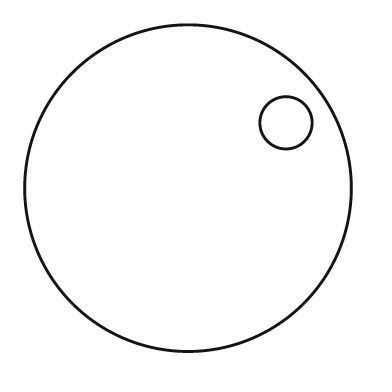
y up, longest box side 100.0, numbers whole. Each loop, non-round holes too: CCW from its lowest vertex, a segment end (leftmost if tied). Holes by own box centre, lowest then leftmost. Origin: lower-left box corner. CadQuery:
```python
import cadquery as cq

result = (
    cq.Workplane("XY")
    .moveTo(50.0, 50.0)
    .circle(50.0)
    .moveTo(80.0, 70.0)
    .circle(8.0)
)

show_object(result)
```